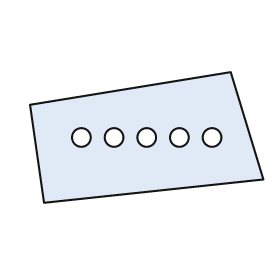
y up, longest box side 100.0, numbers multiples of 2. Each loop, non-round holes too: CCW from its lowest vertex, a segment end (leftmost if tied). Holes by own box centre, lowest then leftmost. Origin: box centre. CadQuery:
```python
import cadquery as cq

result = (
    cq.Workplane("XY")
    .moveTo(-44.0, -28.0)
    .lineTo(50.0, -18.0)
    .lineTo(36.0, 28.0)
    .lineTo(-50.0, 14.0)
    .close()
    .moveTo(-28.0, 0.0)
    .circle(4.0)
    .moveTo(-14.0, 0.0)
    .circle(4.0)
    .moveTo(0.0, 0.0)
    .circle(4.0)
    .moveTo(14.0, 0.0)
    .circle(4.0)
    .moveTo(28.0, 0.0)
    .circle(4.0)
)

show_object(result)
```